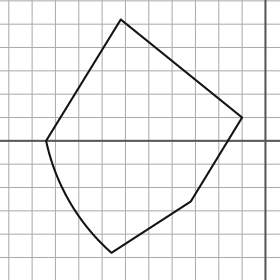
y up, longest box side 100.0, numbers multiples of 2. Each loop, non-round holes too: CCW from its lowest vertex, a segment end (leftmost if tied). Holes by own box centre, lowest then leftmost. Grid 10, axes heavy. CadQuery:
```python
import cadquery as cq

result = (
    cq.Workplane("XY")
    .moveTo(-66.0, -48.0)
    .lineTo(-32.0, -26.0)
    .lineTo(-10.0, 10.0)
    .lineTo(-62.0, 52.0)
    .lineTo(-94.0, 0.0)
    .threePointArc((-84.0, -26.0), (-66.0, -48.0))
    .close()
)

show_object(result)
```